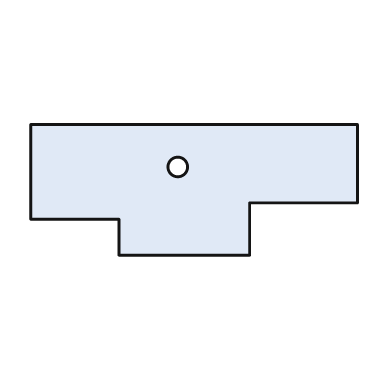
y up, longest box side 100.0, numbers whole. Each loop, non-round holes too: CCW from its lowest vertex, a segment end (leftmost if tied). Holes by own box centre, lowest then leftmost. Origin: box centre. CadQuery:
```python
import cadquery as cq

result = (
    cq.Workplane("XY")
    .moveTo(-23.0, -20.0)
    .lineTo(17.0, -20.0)
    .lineTo(17.0, -4.0)
    .lineTo(50.0, -4.0)
    .lineTo(50.0, 20.0)
    .lineTo(-50.0, 20.0)
    .lineTo(-50.0, -9.0)
    .lineTo(-23.0, -9.0)
    .close()
    .moveTo(-5.0, 7.0)
    .circle(3.0)
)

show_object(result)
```